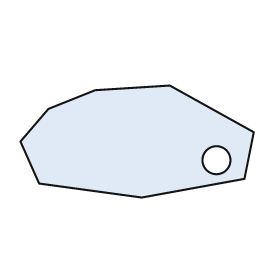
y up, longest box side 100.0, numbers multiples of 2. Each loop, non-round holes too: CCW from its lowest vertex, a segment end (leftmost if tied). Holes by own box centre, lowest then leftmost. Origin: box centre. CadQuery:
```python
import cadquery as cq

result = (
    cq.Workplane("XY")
    .moveTo(2.0, -24.0)
    .lineTo(46.0, -16.0)
    .lineTo(50.0, 4.0)
    .lineTo(14.0, 24.0)
    .lineTo(-18.0, 22.0)
    .lineTo(-38.0, 14.0)
    .lineTo(-50.0, 0.0)
    .lineTo(-42.0, -18.0)
    .close()
    .moveTo(34.0, -8.0)
    .circle(6.0)
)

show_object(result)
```